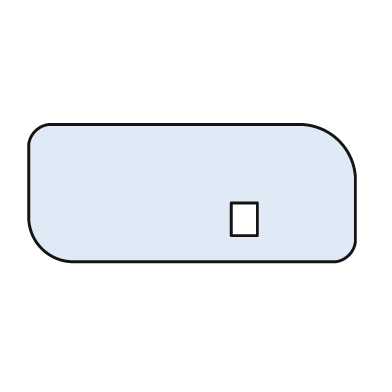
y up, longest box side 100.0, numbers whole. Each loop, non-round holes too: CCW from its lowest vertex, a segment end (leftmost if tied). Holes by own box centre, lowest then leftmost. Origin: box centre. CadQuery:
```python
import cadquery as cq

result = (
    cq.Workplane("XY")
    .moveTo(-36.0, -21.0)
    .lineTo(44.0, -21.0)
    .threePointArc((48.0, -19.0), (50.0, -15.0))
    .lineTo(50.0, 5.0)
    .threePointArc((45.0, 16.0), (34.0, 21.0))
    .lineTo(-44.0, 21.0)
    .threePointArc((-48.0, 19.0), (-50.0, 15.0))
    .lineTo(-50.0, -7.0)
    .threePointArc((-46.0, -17.0), (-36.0, -21.0))
    .close()
    .moveTo(12.0, -13.0)
    .lineTo(20.0, -13.0)
    .lineTo(20.0, -3.0)
    .lineTo(12.0, -3.0)
    .close()
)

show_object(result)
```